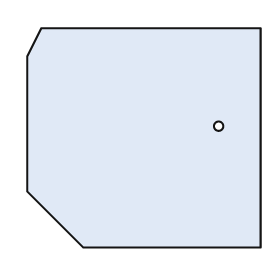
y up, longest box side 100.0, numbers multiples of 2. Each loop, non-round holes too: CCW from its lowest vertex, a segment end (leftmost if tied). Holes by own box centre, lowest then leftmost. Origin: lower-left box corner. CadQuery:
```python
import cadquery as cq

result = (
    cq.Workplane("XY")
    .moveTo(24.0, 0.0)
    .lineTo(100.0, 0.0)
    .lineTo(100.0, 94.0)
    .lineTo(6.0, 94.0)
    .lineTo(0.0, 82.0)
    .lineTo(0.0, 24.0)
    .close()
    .moveTo(82.0, 52.0)
    .circle(2.0)
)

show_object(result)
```